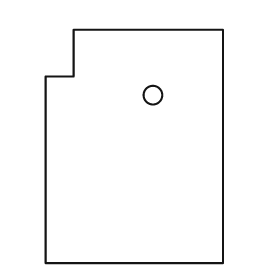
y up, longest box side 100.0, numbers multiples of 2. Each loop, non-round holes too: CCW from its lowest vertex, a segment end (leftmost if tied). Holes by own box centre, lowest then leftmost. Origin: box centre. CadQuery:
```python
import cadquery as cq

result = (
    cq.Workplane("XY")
    .moveTo(-38.0, -50.0)
    .lineTo(38.0, -50.0)
    .lineTo(38.0, 50.0)
    .lineTo(-26.0, 50.0)
    .lineTo(-26.0, 30.0)
    .lineTo(-38.0, 30.0)
    .close()
    .moveTo(8.0, 22.0)
    .circle(4.0)
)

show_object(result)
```